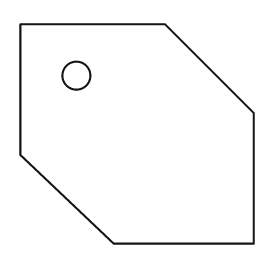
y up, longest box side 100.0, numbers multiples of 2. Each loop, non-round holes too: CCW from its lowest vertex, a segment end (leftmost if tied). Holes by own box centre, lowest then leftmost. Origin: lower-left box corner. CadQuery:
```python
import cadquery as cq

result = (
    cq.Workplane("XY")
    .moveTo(40.0, 0.0)
    .lineTo(100.0, 0.0)
    .lineTo(100.0, 56.0)
    .lineTo(62.0, 94.0)
    .lineTo(0.0, 94.0)
    .lineTo(0.0, 38.0)
    .close()
    .moveTo(24.0, 72.0)
    .circle(6.0)
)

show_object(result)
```